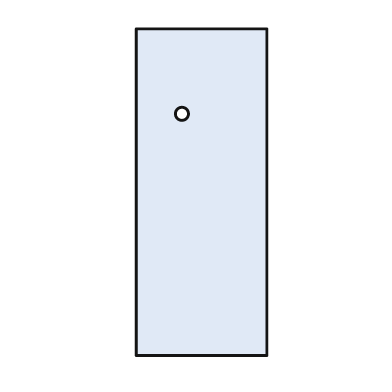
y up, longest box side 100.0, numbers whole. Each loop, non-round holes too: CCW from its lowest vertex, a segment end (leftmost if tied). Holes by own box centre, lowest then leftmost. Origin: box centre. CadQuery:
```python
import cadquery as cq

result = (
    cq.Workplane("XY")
    .moveTo(-20.0, -50.0)
    .lineTo(20.0, -50.0)
    .lineTo(20.0, 50.0)
    .lineTo(-20.0, 50.0)
    .close()
    .moveTo(-6.0, 24.0)
    .circle(2.0)
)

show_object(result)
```